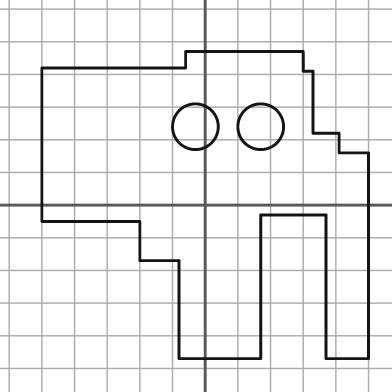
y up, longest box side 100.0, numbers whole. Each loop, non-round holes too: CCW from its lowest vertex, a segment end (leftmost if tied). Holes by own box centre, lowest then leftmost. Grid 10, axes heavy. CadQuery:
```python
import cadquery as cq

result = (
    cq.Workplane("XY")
    .moveTo(-8.0, -47.0)
    .lineTo(17.0, -47.0)
    .lineTo(17.0, -3.0)
    .lineTo(37.0, -3.0)
    .lineTo(37.0, -47.0)
    .lineTo(50.0, -47.0)
    .lineTo(50.0, 16.0)
    .lineTo(41.0, 16.0)
    .lineTo(41.0, 22.0)
    .lineTo(33.0, 22.0)
    .lineTo(33.0, 41.0)
    .lineTo(30.0, 41.0)
    .lineTo(30.0, 47.0)
    .lineTo(-6.0, 47.0)
    .lineTo(-6.0, 42.0)
    .lineTo(-50.0, 42.0)
    .lineTo(-50.0, -5.0)
    .lineTo(-20.0, -5.0)
    .lineTo(-20.0, -17.0)
    .lineTo(-8.0, -17.0)
    .close()
    .moveTo(-3.0, 24.0)
    .circle(7.0)
    .moveTo(17.0, 24.0)
    .circle(7.0)
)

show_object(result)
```